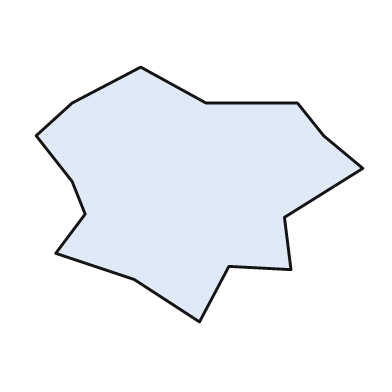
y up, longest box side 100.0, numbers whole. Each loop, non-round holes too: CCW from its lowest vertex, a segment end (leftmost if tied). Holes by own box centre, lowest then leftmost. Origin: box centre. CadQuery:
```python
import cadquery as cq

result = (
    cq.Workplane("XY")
    .moveTo(0.0, -39.0)
    .lineTo(9.0, -22.0)
    .lineTo(28.0, -23.0)
    .lineTo(26.0, -7.0)
    .lineTo(50.0, 8.0)
    .lineTo(38.0, 18.0)
    .lineTo(30.0, 28.0)
    .lineTo(2.0, 28.0)
    .lineTo(-18.0, 39.0)
    .lineTo(-39.0, 28.0)
    .lineTo(-50.0, 18.0)
    .lineTo(-39.0, 4.0)
    .lineTo(-35.0, -6.0)
    .lineTo(-44.0, -18.0)
    .lineTo(-20.0, -26.0)
    .close()
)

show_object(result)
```